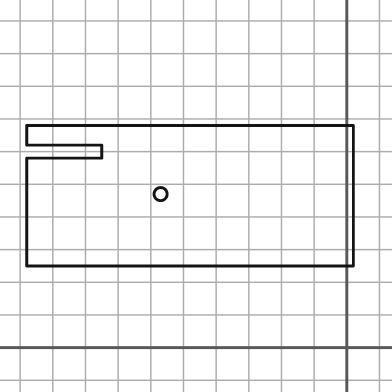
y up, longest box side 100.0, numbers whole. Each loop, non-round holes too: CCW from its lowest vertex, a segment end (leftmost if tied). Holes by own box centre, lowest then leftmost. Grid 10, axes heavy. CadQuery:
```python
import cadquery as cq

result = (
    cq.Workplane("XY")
    .moveTo(-98.0, 25.0)
    .lineTo(2.0, 25.0)
    .lineTo(2.0, 68.0)
    .lineTo(-98.0, 68.0)
    .lineTo(-98.0, 62.0)
    .lineTo(-75.0, 62.0)
    .lineTo(-75.0, 58.0)
    .lineTo(-98.0, 58.0)
    .close()
    .moveTo(-57.0, 47.0)
    .circle(2.0)
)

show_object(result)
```